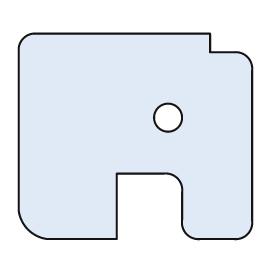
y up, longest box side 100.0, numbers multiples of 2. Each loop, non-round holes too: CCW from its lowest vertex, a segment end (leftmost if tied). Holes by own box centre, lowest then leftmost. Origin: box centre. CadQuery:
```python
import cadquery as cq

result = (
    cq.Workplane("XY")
    .moveTo(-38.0, -44.0)
    .lineTo(-8.0, -44.0)
    .lineTo(-8.0, -16.0)
    .lineTo(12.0, -16.0)
    .threePointArc((18.0, -18.0), (20.0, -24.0))
    .lineTo(20.0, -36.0)
    .threePointArc((22.0, -42.0), (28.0, -44.0))
    .lineTo(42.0, -44.0)
    .threePointArc((48.0, -42.0), (50.0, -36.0))
    .lineTo(50.0, 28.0)
    .threePointArc((48.0, 34.0), (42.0, 36.0))
    .lineTo(32.0, 36.0)
    .lineTo(32.0, 44.0)
    .lineTo(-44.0, 44.0)
    .threePointArc((-48.0, 42.0), (-50.0, 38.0))
    .lineTo(-50.0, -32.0)
    .threePointArc((-46.0, -40.0), (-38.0, -44.0))
    .close()
    .moveTo(14.0, 8.0)
    .circle(6.0)
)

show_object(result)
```